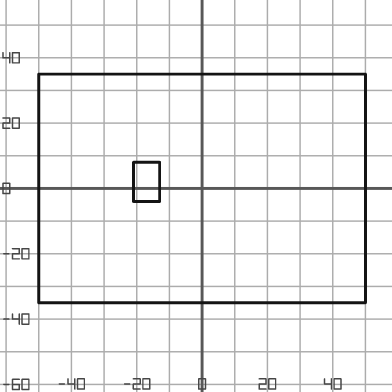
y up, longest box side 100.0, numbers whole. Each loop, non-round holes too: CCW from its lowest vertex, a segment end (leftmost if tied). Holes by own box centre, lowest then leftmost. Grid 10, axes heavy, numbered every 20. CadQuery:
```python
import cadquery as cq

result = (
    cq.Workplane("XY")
    .moveTo(-50.0, -35.0)
    .lineTo(50.0, -35.0)
    .lineTo(50.0, 35.0)
    .lineTo(-50.0, 35.0)
    .close()
    .moveTo(-21.0, -4.0)
    .lineTo(-13.0, -4.0)
    .lineTo(-13.0, 8.0)
    .lineTo(-21.0, 8.0)
    .close()
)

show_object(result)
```